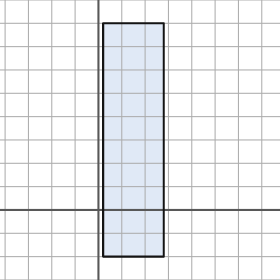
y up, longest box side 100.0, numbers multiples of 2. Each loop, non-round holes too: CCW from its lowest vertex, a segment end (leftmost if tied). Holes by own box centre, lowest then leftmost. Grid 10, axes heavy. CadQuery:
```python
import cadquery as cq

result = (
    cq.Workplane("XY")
    .moveTo(2.0, -20.0)
    .lineTo(28.0, -20.0)
    .lineTo(28.0, 80.0)
    .lineTo(2.0, 80.0)
    .close()
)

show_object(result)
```